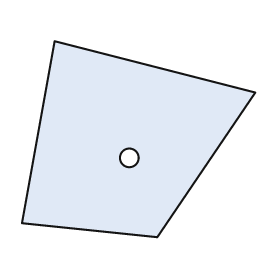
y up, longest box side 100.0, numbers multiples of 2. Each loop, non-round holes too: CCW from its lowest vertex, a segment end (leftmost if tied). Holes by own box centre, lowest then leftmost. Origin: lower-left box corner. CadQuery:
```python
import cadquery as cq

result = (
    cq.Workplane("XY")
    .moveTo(58.0, 0.0)
    .lineTo(100.0, 62.0)
    .lineTo(14.0, 84.0)
    .lineTo(0.0, 6.0)
    .close()
    .moveTo(46.0, 34.0)
    .circle(4.0)
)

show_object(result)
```